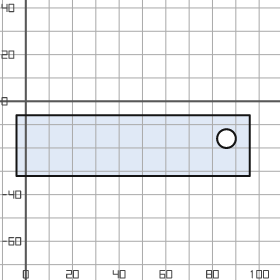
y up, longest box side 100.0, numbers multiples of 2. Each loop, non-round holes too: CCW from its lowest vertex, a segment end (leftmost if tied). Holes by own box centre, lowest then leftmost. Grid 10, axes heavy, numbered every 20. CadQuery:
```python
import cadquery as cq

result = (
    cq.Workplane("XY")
    .moveTo(-4.0, -32.0)
    .lineTo(96.0, -32.0)
    .lineTo(96.0, -6.0)
    .lineTo(-4.0, -6.0)
    .close()
    .moveTo(86.0, -16.0)
    .circle(4.0)
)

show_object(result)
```